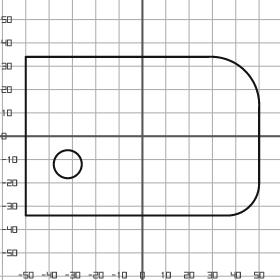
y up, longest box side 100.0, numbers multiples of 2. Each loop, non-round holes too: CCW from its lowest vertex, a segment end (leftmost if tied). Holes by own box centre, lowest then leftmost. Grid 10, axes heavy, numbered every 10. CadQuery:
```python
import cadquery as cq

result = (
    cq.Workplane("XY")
    .moveTo(-50.0, -34.0)
    .lineTo(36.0, -34.0)
    .threePointArc((46.0, -30.0), (50.0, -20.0))
    .lineTo(50.0, 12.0)
    .threePointArc((44.0, 28.0), (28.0, 34.0))
    .lineTo(-50.0, 34.0)
    .close()
    .moveTo(-32.0, -12.0)
    .circle(6.0)
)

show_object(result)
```